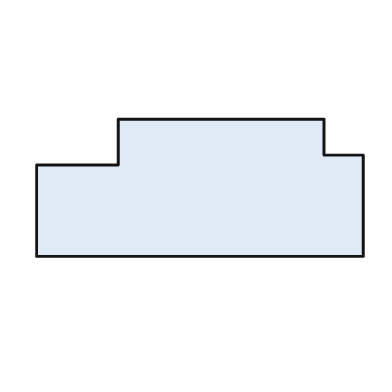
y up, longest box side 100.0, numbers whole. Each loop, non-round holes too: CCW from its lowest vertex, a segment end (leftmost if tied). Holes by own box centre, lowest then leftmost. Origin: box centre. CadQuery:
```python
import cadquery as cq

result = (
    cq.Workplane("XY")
    .moveTo(-50.0, -21.0)
    .lineTo(50.0, -21.0)
    .lineTo(50.0, 10.0)
    .lineTo(38.0, 10.0)
    .lineTo(38.0, 21.0)
    .lineTo(-25.0, 21.0)
    .lineTo(-25.0, 7.0)
    .lineTo(-50.0, 7.0)
    .close()
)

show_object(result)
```